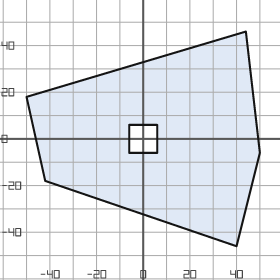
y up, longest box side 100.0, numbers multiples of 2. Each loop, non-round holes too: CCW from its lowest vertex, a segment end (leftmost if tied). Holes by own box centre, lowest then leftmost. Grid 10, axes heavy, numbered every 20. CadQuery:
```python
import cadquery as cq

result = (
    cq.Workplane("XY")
    .moveTo(40.0, -46.0)
    .lineTo(50.0, -6.0)
    .lineTo(44.0, 46.0)
    .lineTo(-50.0, 18.0)
    .lineTo(-42.0, -18.0)
    .close()
    .moveTo(-6.0, -6.0)
    .lineTo(6.0, -6.0)
    .lineTo(6.0, 6.0)
    .lineTo(-6.0, 6.0)
    .close()
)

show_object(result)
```